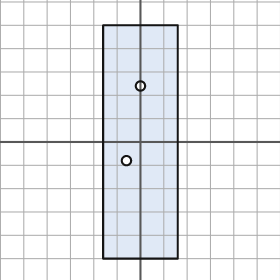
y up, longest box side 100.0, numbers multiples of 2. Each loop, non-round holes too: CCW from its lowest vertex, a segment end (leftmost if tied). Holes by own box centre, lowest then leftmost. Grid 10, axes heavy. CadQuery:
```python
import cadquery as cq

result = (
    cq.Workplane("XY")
    .moveTo(-16.0, -50.0)
    .lineTo(16.0, -50.0)
    .lineTo(16.0, 50.0)
    .lineTo(-16.0, 50.0)
    .close()
    .moveTo(-6.0, -8.0)
    .circle(2.0)
    .moveTo(0.0, 24.0)
    .circle(2.0)
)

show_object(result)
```